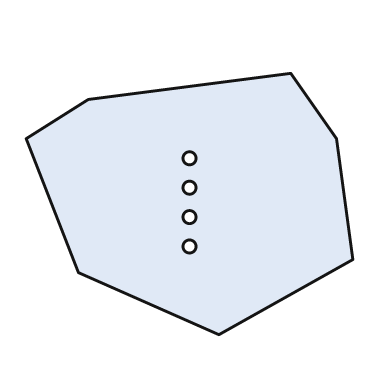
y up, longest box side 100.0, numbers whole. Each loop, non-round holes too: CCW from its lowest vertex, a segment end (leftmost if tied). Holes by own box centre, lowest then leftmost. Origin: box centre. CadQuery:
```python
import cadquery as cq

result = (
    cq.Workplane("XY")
    .moveTo(9.0, -40.0)
    .lineTo(50.0, -17.0)
    .lineTo(45.0, 20.0)
    .lineTo(31.0, 40.0)
    .lineTo(-31.0, 32.0)
    .lineTo(-50.0, 20.0)
    .lineTo(-34.0, -21.0)
    .close()
    .moveTo(0.0, -13.0)
    .circle(2.0)
    .moveTo(0.0, -4.0)
    .circle(2.0)
    .moveTo(0.0, 5.0)
    .circle(2.0)
    .moveTo(0.0, 14.0)
    .circle(2.0)
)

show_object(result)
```